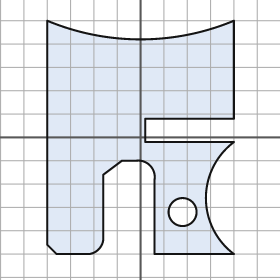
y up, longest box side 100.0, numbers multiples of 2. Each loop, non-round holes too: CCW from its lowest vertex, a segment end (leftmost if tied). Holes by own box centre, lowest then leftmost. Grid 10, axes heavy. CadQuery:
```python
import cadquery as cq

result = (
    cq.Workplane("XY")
    .moveTo(-36.0, -50.0)
    .lineTo(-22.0, -50.0)
    .threePointArc((-18.0, -48.0), (-16.0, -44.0))
    .lineTo(-16.0, -16.0)
    .lineTo(-8.0, -10.0)
    .lineTo(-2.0, -10.0)
    .threePointArc((4.0, -12.0), (6.0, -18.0))
    .lineTo(6.0, -50.0)
    .lineTo(40.0, -50.0)
    .threePointArc((28.0, -26.0), (40.0, -2.0))
    .lineTo(2.0, -2.0)
    .lineTo(2.0, 8.0)
    .lineTo(40.0, 8.0)
    .lineTo(40.0, 50.0)
    .threePointArc((0.0, 42.0), (-40.0, 50.0))
    .lineTo(-40.0, -46.0)
    .close()
    .moveTo(18.0, -32.0)
    .circle(6.0)
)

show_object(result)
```